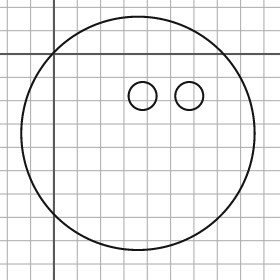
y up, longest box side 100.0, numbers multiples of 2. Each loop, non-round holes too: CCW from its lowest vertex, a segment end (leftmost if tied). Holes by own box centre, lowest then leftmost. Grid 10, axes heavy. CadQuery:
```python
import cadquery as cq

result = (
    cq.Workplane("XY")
    .moveTo(36.0, -34.0)
    .circle(50.0)
    .moveTo(38.0, -18.0)
    .circle(6.0)
    .moveTo(58.0, -18.0)
    .circle(6.0)
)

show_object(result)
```